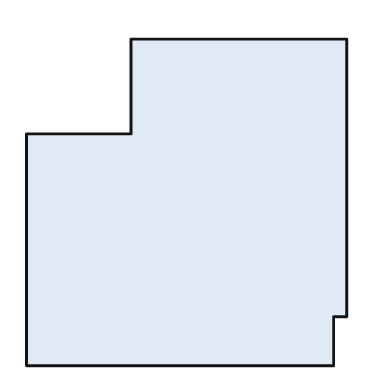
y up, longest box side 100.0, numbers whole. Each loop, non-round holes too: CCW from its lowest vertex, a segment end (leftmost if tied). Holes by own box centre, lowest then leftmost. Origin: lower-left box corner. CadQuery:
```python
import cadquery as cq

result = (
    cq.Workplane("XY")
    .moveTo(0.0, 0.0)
    .lineTo(94.0, 0.0)
    .lineTo(94.0, 15.0)
    .lineTo(98.0, 15.0)
    .lineTo(98.0, 100.0)
    .lineTo(32.0, 100.0)
    .lineTo(32.0, 71.0)
    .lineTo(0.0, 71.0)
    .close()
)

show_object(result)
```